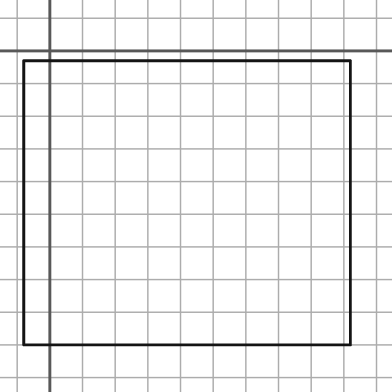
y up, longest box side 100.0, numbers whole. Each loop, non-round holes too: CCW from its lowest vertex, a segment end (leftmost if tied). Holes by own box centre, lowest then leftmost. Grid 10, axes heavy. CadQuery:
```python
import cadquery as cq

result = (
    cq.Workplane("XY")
    .moveTo(-8.0, -90.0)
    .lineTo(92.0, -90.0)
    .lineTo(92.0, -3.0)
    .lineTo(-8.0, -3.0)
    .close()
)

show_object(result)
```